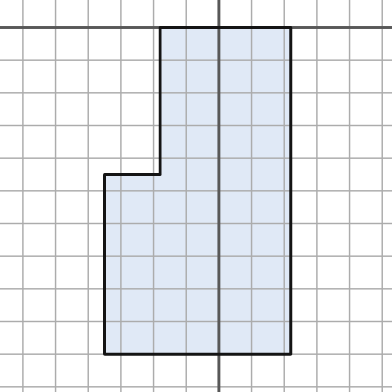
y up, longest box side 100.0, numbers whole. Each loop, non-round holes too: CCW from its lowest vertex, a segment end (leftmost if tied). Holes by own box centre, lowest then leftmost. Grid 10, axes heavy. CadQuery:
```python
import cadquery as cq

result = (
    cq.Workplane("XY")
    .moveTo(-35.0, -100.0)
    .lineTo(22.0, -100.0)
    .lineTo(22.0, 0.0)
    .lineTo(-18.0, 0.0)
    .lineTo(-18.0, -45.0)
    .lineTo(-35.0, -45.0)
    .close()
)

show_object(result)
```